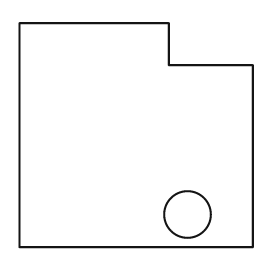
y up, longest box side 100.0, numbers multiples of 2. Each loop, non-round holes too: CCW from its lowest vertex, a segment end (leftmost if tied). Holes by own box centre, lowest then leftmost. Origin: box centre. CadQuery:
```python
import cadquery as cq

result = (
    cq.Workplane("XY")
    .moveTo(-50.0, -48.0)
    .lineTo(50.0, -48.0)
    .lineTo(50.0, 30.0)
    .lineTo(14.0, 30.0)
    .lineTo(14.0, 48.0)
    .lineTo(-50.0, 48.0)
    .close()
    .moveTo(22.0, -34.0)
    .circle(10.0)
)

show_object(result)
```